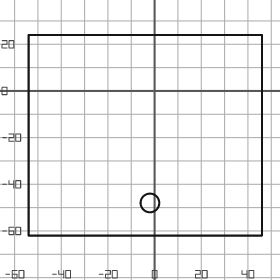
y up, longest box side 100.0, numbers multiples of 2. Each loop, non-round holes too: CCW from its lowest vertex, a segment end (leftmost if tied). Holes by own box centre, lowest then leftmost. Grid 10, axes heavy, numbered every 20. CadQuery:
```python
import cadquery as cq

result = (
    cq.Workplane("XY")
    .moveTo(-54.0, -62.0)
    .lineTo(46.0, -62.0)
    .lineTo(46.0, 24.0)
    .lineTo(-54.0, 24.0)
    .close()
    .moveTo(-2.0, -48.0)
    .circle(4.0)
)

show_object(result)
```